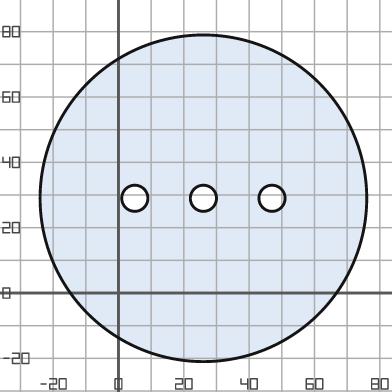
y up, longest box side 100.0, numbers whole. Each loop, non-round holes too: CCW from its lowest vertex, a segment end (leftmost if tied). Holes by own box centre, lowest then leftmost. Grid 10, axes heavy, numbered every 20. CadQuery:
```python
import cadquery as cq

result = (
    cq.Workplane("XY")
    .moveTo(26.0, 29.0)
    .circle(50.0)
    .moveTo(5.0, 29.0)
    .circle(4.0)
    .moveTo(26.0, 29.0)
    .circle(4.0)
    .moveTo(47.0, 29.0)
    .circle(4.0)
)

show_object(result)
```